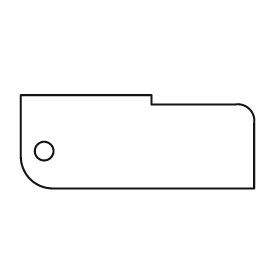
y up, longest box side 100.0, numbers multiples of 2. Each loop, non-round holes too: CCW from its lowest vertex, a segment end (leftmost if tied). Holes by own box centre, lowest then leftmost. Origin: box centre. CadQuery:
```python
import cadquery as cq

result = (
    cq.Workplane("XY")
    .moveTo(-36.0, -20.0)
    .lineTo(50.0, -20.0)
    .lineTo(50.0, 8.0)
    .threePointArc((48.0, 14.0), (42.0, 16.0))
    .lineTo(6.0, 16.0)
    .lineTo(6.0, 20.0)
    .lineTo(-50.0, 20.0)
    .lineTo(-50.0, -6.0)
    .threePointArc((-46.0, -16.0), (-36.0, -20.0))
    .close()
    .moveTo(-40.0, -4.0)
    .circle(4.0)
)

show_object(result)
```